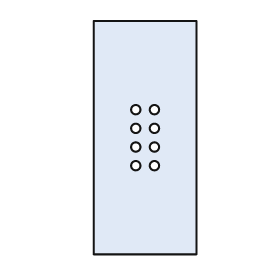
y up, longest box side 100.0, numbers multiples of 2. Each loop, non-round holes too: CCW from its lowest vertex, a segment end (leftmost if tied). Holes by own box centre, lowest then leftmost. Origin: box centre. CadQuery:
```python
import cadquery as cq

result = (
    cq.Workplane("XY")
    .moveTo(-22.0, -50.0)
    .lineTo(22.0, -50.0)
    .lineTo(22.0, 50.0)
    .lineTo(-22.0, 50.0)
    .close()
    .moveTo(-4.0, -12.0)
    .circle(2.0)
    .moveTo(4.0, -12.0)
    .circle(2.0)
    .moveTo(-4.0, -4.0)
    .circle(2.0)
    .moveTo(4.0, -4.0)
    .circle(2.0)
    .moveTo(-4.0, 4.0)
    .circle(2.0)
    .moveTo(4.0, 4.0)
    .circle(2.0)
    .moveTo(-4.0, 12.0)
    .circle(2.0)
    .moveTo(4.0, 12.0)
    .circle(2.0)
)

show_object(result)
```